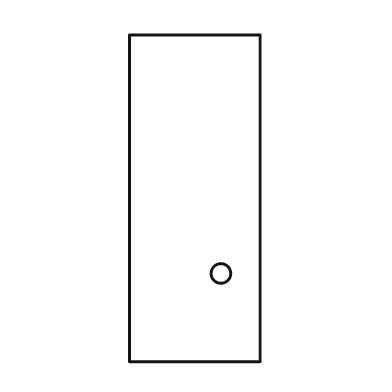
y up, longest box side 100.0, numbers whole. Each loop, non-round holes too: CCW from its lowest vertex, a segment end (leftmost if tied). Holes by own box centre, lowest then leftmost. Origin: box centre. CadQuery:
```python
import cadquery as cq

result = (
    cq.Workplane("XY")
    .moveTo(-20.0, -50.0)
    .lineTo(20.0, -50.0)
    .lineTo(20.0, 50.0)
    .lineTo(-20.0, 50.0)
    .close()
    .moveTo(8.0, -23.0)
    .circle(3.0)
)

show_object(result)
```